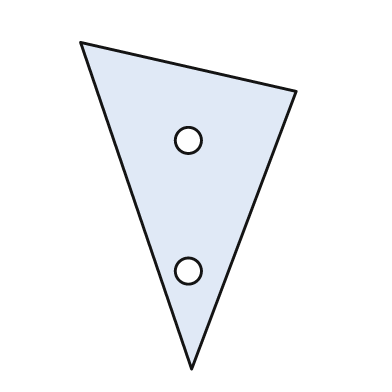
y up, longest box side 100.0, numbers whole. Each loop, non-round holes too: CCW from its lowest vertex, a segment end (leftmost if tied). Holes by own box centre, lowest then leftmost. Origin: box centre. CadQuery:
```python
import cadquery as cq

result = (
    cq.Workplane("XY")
    .moveTo(1.0, -50.0)
    .lineTo(33.0, 35.0)
    .lineTo(-33.0, 50.0)
    .close()
    .moveTo(0.0, -20.0)
    .circle(4.0)
    .moveTo(0.0, 20.0)
    .circle(4.0)
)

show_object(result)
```